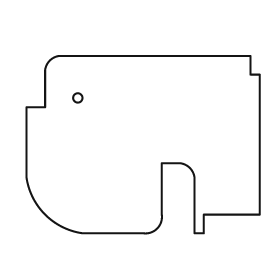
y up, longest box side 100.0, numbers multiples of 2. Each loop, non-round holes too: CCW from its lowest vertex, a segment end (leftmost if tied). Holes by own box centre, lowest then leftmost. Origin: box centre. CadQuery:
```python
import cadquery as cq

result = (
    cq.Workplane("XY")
    .moveTo(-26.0, -38.0)
    .lineTo(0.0, -38.0)
    .threePointArc((6.0, -36.0), (8.0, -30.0))
    .lineTo(8.0, -8.0)
    .lineTo(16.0, -8.0)
    .threePointArc((20.0, -10.0), (22.0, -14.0))
    .lineTo(22.0, -38.0)
    .lineTo(26.0, -38.0)
    .lineTo(26.0, -30.0)
    .lineTo(50.0, -30.0)
    .lineTo(50.0, 30.0)
    .lineTo(46.0, 30.0)
    .lineTo(46.0, 38.0)
    .lineTo(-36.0, 38.0)
    .threePointArc((-40.0, 36.0), (-42.0, 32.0))
    .lineTo(-42.0, 16.0)
    .lineTo(-50.0, 16.0)
    .lineTo(-50.0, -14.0)
    .threePointArc((-42.0, -30.0), (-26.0, -38.0))
    .close()
    .moveTo(-28.0, 20.0)
    .circle(2.0)
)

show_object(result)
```